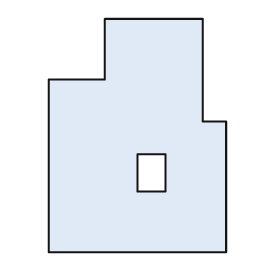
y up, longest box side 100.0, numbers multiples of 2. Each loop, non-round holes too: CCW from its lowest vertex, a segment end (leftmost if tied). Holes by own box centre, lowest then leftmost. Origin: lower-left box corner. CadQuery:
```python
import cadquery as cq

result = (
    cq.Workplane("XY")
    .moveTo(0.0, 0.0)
    .lineTo(76.0, 0.0)
    .lineTo(76.0, 56.0)
    .lineTo(66.0, 56.0)
    .lineTo(66.0, 100.0)
    .lineTo(24.0, 100.0)
    .lineTo(24.0, 74.0)
    .lineTo(0.0, 74.0)
    .close()
    .moveTo(38.0, 26.0)
    .lineTo(50.0, 26.0)
    .lineTo(50.0, 42.0)
    .lineTo(38.0, 42.0)
    .close()
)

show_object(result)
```